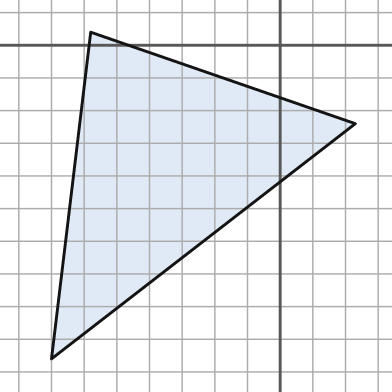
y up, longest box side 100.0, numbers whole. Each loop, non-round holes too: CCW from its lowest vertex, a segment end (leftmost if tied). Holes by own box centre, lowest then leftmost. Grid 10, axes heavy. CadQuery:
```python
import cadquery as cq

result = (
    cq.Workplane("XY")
    .moveTo(-70.0, -96.0)
    .lineTo(23.0, -24.0)
    .lineTo(-58.0, 4.0)
    .close()
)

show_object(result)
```